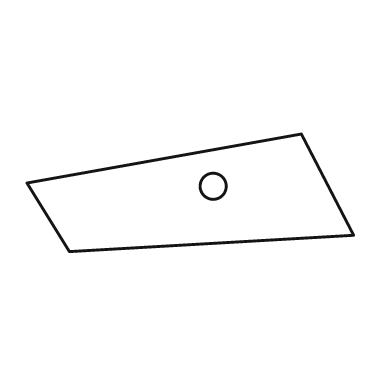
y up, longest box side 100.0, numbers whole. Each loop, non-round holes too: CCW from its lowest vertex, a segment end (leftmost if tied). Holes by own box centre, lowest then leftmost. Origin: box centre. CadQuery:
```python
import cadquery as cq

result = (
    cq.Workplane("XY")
    .moveTo(-37.0, -18.0)
    .lineTo(50.0, -13.0)
    .lineTo(34.0, 18.0)
    .lineTo(-50.0, 3.0)
    .close()
    .moveTo(7.0, 2.0)
    .circle(4.0)
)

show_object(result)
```